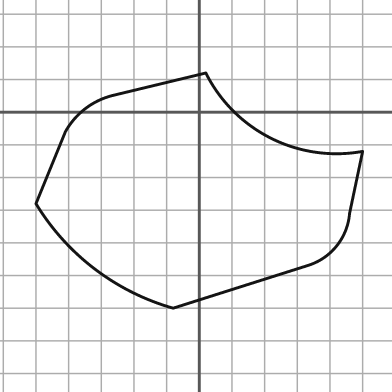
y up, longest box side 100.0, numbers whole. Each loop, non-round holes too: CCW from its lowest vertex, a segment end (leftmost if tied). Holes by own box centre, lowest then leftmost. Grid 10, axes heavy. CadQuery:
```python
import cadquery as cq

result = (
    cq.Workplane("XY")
    .moveTo(-8.0, -60.0)
    .lineTo(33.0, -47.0)
    .threePointArc((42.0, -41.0), (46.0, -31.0))
    .lineTo(50.0, -12.0)
    .threePointArc((22.0, -8.0), (2.0, 12.0))
    .lineTo(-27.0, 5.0)
    .threePointArc((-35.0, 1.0), (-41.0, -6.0))
    .lineTo(-50.0, -28.0)
    .threePointArc((-32.0, -48.0), (-8.0, -60.0))
    .close()
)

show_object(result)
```